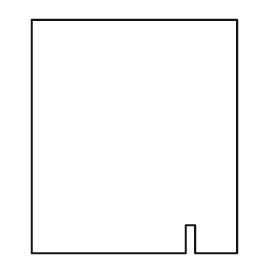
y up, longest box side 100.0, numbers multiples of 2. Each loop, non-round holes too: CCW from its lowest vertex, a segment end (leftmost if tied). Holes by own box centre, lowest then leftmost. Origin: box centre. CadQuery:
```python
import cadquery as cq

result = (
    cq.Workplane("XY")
    .moveTo(-44.0, -50.0)
    .lineTo(22.0, -50.0)
    .lineTo(22.0, -38.0)
    .lineTo(26.0, -38.0)
    .lineTo(26.0, -50.0)
    .lineTo(44.0, -50.0)
    .lineTo(44.0, 50.0)
    .lineTo(-44.0, 50.0)
    .close()
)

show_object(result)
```